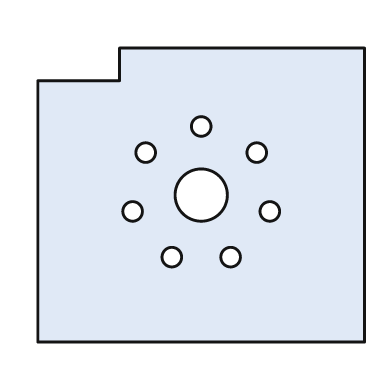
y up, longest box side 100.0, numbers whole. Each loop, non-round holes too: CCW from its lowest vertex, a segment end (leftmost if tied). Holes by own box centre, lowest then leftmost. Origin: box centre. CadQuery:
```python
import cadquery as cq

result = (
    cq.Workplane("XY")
    .moveTo(-50.0, -45.0)
    .lineTo(50.0, -45.0)
    .lineTo(50.0, 45.0)
    .lineTo(-25.0, 45.0)
    .lineTo(-25.0, 35.0)
    .lineTo(-50.0, 35.0)
    .close()
    .moveTo(-9.0, -19.0)
    .circle(3.0)
    .moveTo(9.0, -19.0)
    .circle(3.0)
    .moveTo(-21.0, -5.0)
    .circle(3.0)
    .moveTo(21.0, -5.0)
    .circle(3.0)
    .moveTo(0.0, 0.0)
    .circle(8.0)
    .moveTo(-17.0, 13.0)
    .circle(3.0)
    .moveTo(17.0, 13.0)
    .circle(3.0)
    .moveTo(0.0, 21.0)
    .circle(3.0)
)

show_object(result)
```